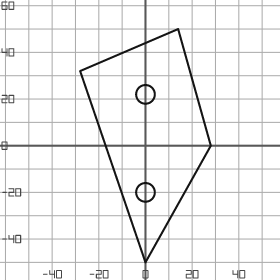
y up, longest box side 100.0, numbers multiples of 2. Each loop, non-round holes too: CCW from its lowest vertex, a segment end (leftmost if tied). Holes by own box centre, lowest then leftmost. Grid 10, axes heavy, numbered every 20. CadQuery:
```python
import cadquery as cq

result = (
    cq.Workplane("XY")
    .moveTo(0.0, -50.0)
    .lineTo(28.0, 0.0)
    .lineTo(14.0, 50.0)
    .lineTo(-28.0, 32.0)
    .close()
    .moveTo(0.0, -20.0)
    .circle(4.0)
    .moveTo(0.0, 22.0)
    .circle(4.0)
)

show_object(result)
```